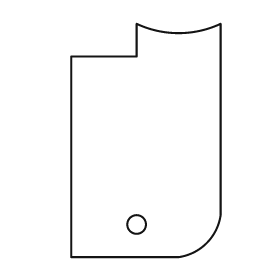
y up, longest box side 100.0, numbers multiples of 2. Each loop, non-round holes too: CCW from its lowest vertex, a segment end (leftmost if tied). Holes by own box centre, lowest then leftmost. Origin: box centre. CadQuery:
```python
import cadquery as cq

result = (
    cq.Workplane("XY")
    .moveTo(-32.0, -50.0)
    .lineTo(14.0, -50.0)
    .threePointArc((26.0, -44.0), (32.0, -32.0))
    .lineTo(32.0, 50.0)
    .threePointArc((14.0, 46.0), (-4.0, 50.0))
    .lineTo(-4.0, 36.0)
    .lineTo(-32.0, 36.0)
    .close()
    .moveTo(-4.0, -36.0)
    .circle(4.0)
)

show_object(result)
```